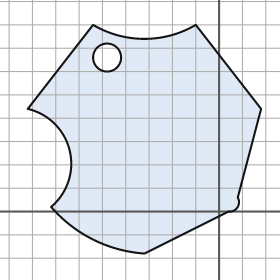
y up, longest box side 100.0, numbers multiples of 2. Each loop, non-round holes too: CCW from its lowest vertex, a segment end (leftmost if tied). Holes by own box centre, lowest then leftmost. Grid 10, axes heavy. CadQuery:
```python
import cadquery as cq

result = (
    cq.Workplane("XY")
    .moveTo(-32.0, -18.0)
    .lineTo(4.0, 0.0)
    .threePointArc((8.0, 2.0), (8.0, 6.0))
    .lineTo(18.0, 44.0)
    .lineTo(-10.0, 80.0)
    .threePointArc((-32.0, 74.0), (-54.0, 80.0))
    .lineTo(-82.0, 44.0)
    .threePointArc((-64.0, 26.0), (-72.0, 2.0))
    .threePointArc((-54.0, -12.0), (-32.0, -18.0))
    .close()
    .moveTo(-48.0, 66.0)
    .circle(6.0)
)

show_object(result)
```